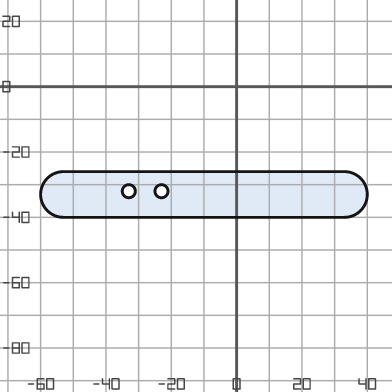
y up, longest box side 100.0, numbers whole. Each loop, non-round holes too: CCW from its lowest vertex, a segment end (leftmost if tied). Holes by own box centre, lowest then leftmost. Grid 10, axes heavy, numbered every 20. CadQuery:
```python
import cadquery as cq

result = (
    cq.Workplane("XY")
    .moveTo(-53.0, -40.0)
    .lineTo(33.0, -40.0)
    .threePointArc((40.0, -33.0), (33.0, -26.0))
    .lineTo(-53.0, -26.0)
    .threePointArc((-60.0, -33.0), (-53.0, -40.0))
    .close()
    .moveTo(-33.0, -32.0)
    .circle(2.0)
    .moveTo(-23.0, -32.0)
    .circle(2.0)
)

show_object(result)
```